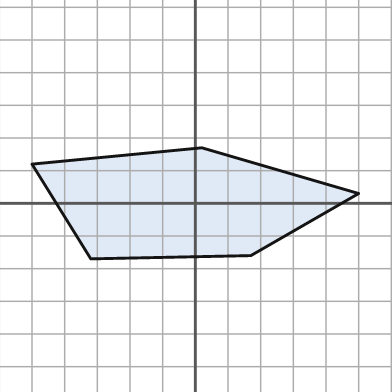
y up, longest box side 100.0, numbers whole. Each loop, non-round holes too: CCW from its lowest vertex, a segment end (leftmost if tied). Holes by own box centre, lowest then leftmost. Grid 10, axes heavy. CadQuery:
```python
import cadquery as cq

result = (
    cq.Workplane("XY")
    .moveTo(-32.0, -17.0)
    .lineTo(17.0, -16.0)
    .lineTo(50.0, 3.0)
    .lineTo(2.0, 17.0)
    .lineTo(-50.0, 12.0)
    .close()
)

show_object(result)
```